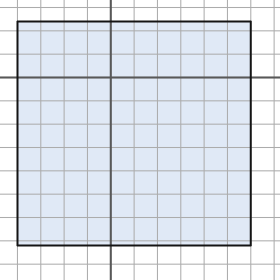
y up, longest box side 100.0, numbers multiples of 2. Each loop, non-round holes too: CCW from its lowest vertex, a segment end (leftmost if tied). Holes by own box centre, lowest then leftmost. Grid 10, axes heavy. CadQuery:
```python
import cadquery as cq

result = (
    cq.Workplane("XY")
    .moveTo(-40.0, -72.0)
    .lineTo(60.0, -72.0)
    .lineTo(60.0, 24.0)
    .lineTo(-40.0, 24.0)
    .close()
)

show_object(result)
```